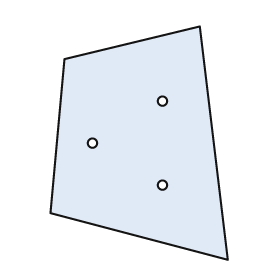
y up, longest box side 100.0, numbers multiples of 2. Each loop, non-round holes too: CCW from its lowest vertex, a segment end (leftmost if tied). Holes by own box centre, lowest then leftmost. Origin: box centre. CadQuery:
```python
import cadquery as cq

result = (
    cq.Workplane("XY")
    .moveTo(38.0, -50.0)
    .lineTo(26.0, 50.0)
    .lineTo(-32.0, 36.0)
    .lineTo(-38.0, -30.0)
    .close()
    .moveTo(10.0, -18.0)
    .circle(2.0)
    .moveTo(-20.0, 0.0)
    .circle(2.0)
    .moveTo(10.0, 18.0)
    .circle(2.0)
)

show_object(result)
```